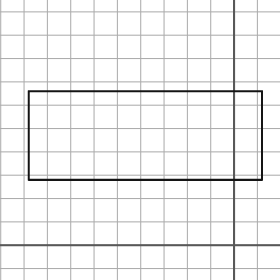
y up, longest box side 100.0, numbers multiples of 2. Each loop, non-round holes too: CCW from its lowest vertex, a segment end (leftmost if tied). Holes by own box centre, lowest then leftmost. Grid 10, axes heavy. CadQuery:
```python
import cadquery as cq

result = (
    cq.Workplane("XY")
    .moveTo(-88.0, 28.0)
    .lineTo(12.0, 28.0)
    .lineTo(12.0, 66.0)
    .lineTo(-88.0, 66.0)
    .close()
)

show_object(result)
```